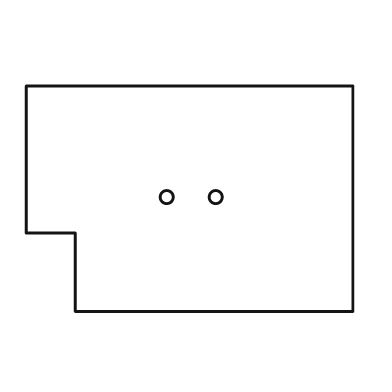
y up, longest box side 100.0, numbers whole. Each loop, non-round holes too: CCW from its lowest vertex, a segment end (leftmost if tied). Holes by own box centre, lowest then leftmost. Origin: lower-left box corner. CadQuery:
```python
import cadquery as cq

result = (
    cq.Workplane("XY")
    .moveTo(15.0, 0.0)
    .lineTo(100.0, 0.0)
    .lineTo(100.0, 69.0)
    .lineTo(0.0, 69.0)
    .lineTo(0.0, 24.0)
    .lineTo(15.0, 24.0)
    .close()
    .moveTo(43.0, 35.0)
    .circle(2.0)
    .moveTo(58.0, 35.0)
    .circle(2.0)
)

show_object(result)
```